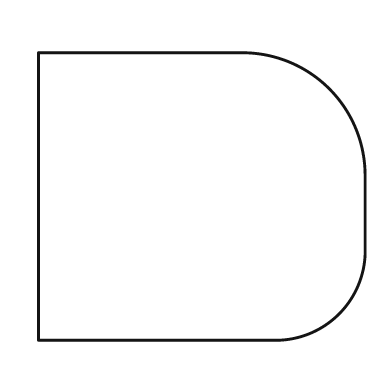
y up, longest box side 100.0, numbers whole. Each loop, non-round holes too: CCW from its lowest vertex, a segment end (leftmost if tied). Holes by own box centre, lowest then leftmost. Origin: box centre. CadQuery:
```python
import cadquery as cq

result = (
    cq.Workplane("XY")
    .moveTo(-50.0, -44.0)
    .lineTo(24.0, -44.0)
    .threePointArc((42.0, -36.0), (50.0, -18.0))
    .lineTo(50.0, 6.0)
    .threePointArc((39.0, 33.0), (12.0, 44.0))
    .lineTo(-50.0, 44.0)
    .close()
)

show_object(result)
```